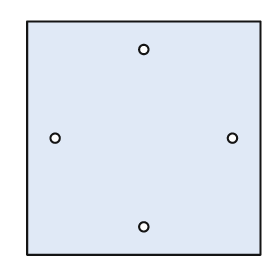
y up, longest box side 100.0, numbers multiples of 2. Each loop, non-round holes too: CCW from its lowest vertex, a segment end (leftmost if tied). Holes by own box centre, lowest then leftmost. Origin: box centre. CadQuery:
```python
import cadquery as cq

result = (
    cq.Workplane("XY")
    .moveTo(-50.0, -50.0)
    .lineTo(50.0, -50.0)
    .lineTo(50.0, 50.0)
    .lineTo(-50.0, 50.0)
    .close()
    .moveTo(0.0, -38.0)
    .circle(2.0)
    .moveTo(-38.0, 0.0)
    .circle(2.0)
    .moveTo(38.0, 0.0)
    .circle(2.0)
    .moveTo(0.0, 38.0)
    .circle(2.0)
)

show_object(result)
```